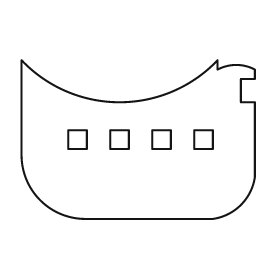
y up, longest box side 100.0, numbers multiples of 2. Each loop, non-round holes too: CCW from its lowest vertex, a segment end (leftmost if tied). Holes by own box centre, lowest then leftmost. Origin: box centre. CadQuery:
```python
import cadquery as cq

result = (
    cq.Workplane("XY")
    .moveTo(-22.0, -34.0)
    .lineTo(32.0, -34.0)
    .threePointArc((44.0, -28.0), (50.0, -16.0))
    .lineTo(50.0, 16.0)
    .lineTo(44.0, 16.0)
    .lineTo(44.0, 26.0)
    .lineTo(50.0, 26.0)
    .lineTo(50.0, 30.0)
    .threePointArc((42.0, 32.0), (34.0, 30.0))
    .lineTo(34.0, 34.0)
    .threePointArc((-8.0, 16.0), (-50.0, 34.0))
    .lineTo(-50.0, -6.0)
    .threePointArc((-42.0, -26.0), (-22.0, -34.0))
    .close()
    .moveTo(-30.0, -4.0)
    .lineTo(-22.0, -4.0)
    .lineTo(-22.0, 4.0)
    .lineTo(-30.0, 4.0)
    .close()
    .moveTo(-12.0, -4.0)
    .lineTo(-4.0, -4.0)
    .lineTo(-4.0, 4.0)
    .lineTo(-12.0, 4.0)
    .close()
    .moveTo(6.0, -4.0)
    .lineTo(14.0, -4.0)
    .lineTo(14.0, 4.0)
    .lineTo(6.0, 4.0)
    .close()
    .moveTo(24.0, -4.0)
    .lineTo(32.0, -4.0)
    .lineTo(32.0, 4.0)
    .lineTo(24.0, 4.0)
    .close()
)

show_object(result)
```